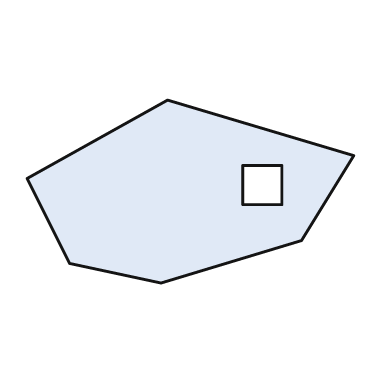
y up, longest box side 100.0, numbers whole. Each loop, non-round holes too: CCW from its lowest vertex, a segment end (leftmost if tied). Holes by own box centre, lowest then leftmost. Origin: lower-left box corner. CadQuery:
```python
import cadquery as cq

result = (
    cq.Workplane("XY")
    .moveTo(41.0, 0.0)
    .lineTo(84.0, 13.0)
    .lineTo(100.0, 39.0)
    .lineTo(43.0, 56.0)
    .lineTo(0.0, 32.0)
    .lineTo(13.0, 6.0)
    .close()
    .moveTo(66.0, 24.0)
    .lineTo(78.0, 24.0)
    .lineTo(78.0, 36.0)
    .lineTo(66.0, 36.0)
    .close()
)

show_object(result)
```